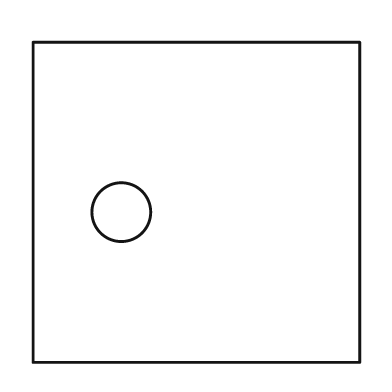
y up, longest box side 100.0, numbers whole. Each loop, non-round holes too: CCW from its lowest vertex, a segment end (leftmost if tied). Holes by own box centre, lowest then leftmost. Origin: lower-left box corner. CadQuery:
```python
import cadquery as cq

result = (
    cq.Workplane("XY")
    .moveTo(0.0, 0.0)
    .lineTo(100.0, 0.0)
    .lineTo(100.0, 98.0)
    .lineTo(0.0, 98.0)
    .close()
    .moveTo(27.0, 46.0)
    .circle(9.0)
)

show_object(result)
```